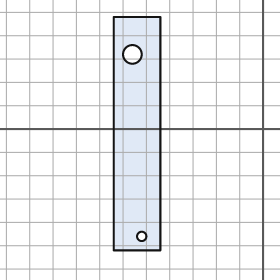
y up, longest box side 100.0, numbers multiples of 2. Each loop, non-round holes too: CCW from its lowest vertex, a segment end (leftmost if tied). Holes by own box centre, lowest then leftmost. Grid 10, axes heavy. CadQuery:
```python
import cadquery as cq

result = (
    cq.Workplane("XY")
    .moveTo(-64.0, -52.0)
    .lineTo(-44.0, -52.0)
    .lineTo(-44.0, 48.0)
    .lineTo(-64.0, 48.0)
    .close()
    .moveTo(-52.0, -46.0)
    .circle(2.0)
    .moveTo(-56.0, 32.0)
    .circle(4.0)
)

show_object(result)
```